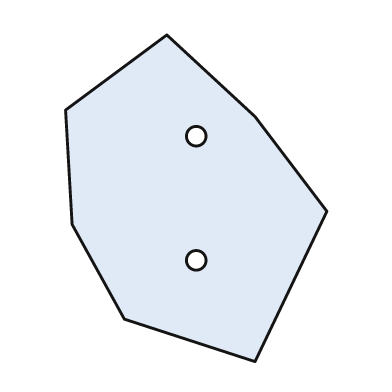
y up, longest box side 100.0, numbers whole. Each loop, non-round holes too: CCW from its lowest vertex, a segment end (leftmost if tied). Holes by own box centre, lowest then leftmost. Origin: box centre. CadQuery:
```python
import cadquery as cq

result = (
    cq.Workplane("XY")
    .moveTo(18.0, -50.0)
    .lineTo(40.0, -4.0)
    .lineTo(18.0, 25.0)
    .lineTo(-9.0, 50.0)
    .lineTo(-40.0, 27.0)
    .lineTo(-38.0, -8.0)
    .lineTo(-22.0, -37.0)
    .close()
    .moveTo(0.0, -19.0)
    .circle(3.0)
    .moveTo(0.0, 19.0)
    .circle(3.0)
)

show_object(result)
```